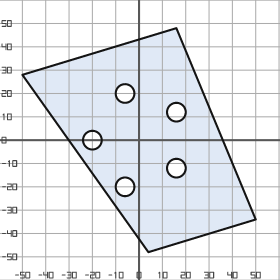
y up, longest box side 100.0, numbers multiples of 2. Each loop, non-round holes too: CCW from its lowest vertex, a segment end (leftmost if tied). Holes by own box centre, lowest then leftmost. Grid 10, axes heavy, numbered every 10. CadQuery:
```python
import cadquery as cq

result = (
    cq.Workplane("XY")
    .moveTo(4.0, -48.0)
    .lineTo(50.0, -34.0)
    .lineTo(16.0, 48.0)
    .lineTo(-50.0, 28.0)
    .close()
    .moveTo(-6.0, -20.0)
    .circle(4.0)
    .moveTo(16.0, -12.0)
    .circle(4.0)
    .moveTo(-20.0, 0.0)
    .circle(4.0)
    .moveTo(16.0, 12.0)
    .circle(4.0)
    .moveTo(-6.0, 20.0)
    .circle(4.0)
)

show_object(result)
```